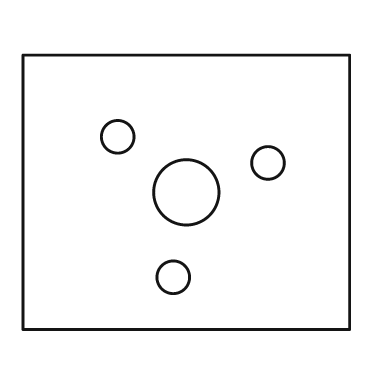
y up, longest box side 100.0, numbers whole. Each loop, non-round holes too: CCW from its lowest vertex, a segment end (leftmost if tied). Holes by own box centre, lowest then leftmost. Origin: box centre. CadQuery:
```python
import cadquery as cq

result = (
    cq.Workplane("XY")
    .moveTo(-50.0, -42.0)
    .lineTo(50.0, -42.0)
    .lineTo(50.0, 42.0)
    .lineTo(-50.0, 42.0)
    .close()
    .moveTo(-4.0, -26.0)
    .circle(5.0)
    .moveTo(0.0, 0.0)
    .circle(10.0)
    .moveTo(25.0, 9.0)
    .circle(5.0)
    .moveTo(-21.0, 17.0)
    .circle(5.0)
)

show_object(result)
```